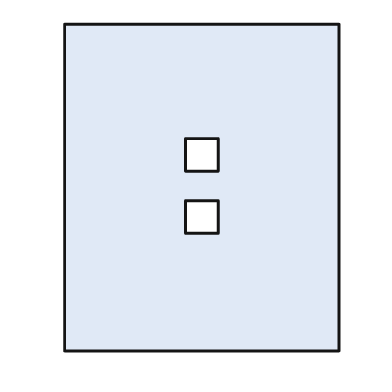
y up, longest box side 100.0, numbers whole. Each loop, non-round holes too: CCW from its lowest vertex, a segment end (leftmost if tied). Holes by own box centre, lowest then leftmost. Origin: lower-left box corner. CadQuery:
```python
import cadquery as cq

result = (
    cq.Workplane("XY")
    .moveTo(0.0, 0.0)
    .lineTo(84.0, 0.0)
    .lineTo(84.0, 100.0)
    .lineTo(0.0, 100.0)
    .close()
    .moveTo(37.0, 36.0)
    .lineTo(47.0, 36.0)
    .lineTo(47.0, 46.0)
    .lineTo(37.0, 46.0)
    .close()
    .moveTo(37.0, 55.0)
    .lineTo(47.0, 55.0)
    .lineTo(47.0, 65.0)
    .lineTo(37.0, 65.0)
    .close()
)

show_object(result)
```